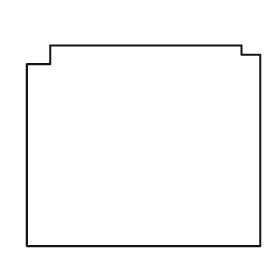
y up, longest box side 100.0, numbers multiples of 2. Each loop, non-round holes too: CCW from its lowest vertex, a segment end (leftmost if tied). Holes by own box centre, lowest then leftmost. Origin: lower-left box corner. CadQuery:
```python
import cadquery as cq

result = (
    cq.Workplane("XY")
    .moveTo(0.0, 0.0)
    .lineTo(100.0, 0.0)
    .lineTo(100.0, 82.0)
    .lineTo(92.0, 82.0)
    .lineTo(92.0, 86.0)
    .lineTo(10.0, 86.0)
    .lineTo(10.0, 78.0)
    .lineTo(0.0, 78.0)
    .close()
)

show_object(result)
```